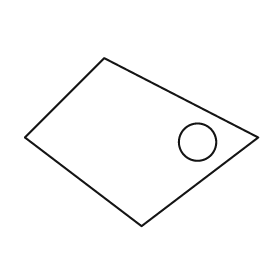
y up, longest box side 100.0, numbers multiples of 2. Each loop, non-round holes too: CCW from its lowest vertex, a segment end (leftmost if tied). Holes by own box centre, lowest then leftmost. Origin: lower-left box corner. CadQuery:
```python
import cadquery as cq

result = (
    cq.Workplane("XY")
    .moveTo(50.0, 0.0)
    .lineTo(100.0, 38.0)
    .lineTo(34.0, 72.0)
    .lineTo(0.0, 38.0)
    .close()
    .moveTo(74.0, 36.0)
    .circle(8.0)
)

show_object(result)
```